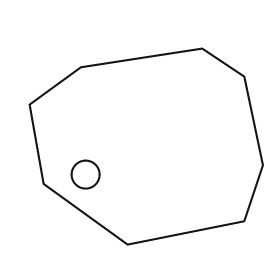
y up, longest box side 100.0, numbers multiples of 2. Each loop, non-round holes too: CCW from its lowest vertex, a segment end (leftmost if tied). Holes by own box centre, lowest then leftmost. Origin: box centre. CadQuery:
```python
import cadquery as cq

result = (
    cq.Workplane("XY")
    .moveTo(-8.0, -42.0)
    .lineTo(42.0, -32.0)
    .lineTo(50.0, -8.0)
    .lineTo(42.0, 30.0)
    .lineTo(24.0, 42.0)
    .lineTo(-28.0, 34.0)
    .lineTo(-50.0, 18.0)
    .lineTo(-44.0, -16.0)
    .close()
    .moveTo(-26.0, -12.0)
    .circle(6.0)
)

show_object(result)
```